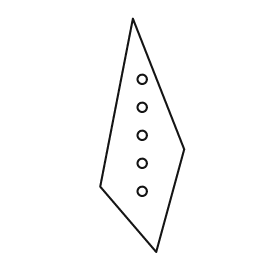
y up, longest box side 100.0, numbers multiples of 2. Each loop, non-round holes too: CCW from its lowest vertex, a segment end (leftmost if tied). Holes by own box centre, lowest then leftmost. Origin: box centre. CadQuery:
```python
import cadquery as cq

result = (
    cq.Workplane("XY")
    .moveTo(6.0, -50.0)
    .lineTo(18.0, -6.0)
    .lineTo(-4.0, 50.0)
    .lineTo(-18.0, -22.0)
    .close()
    .moveTo(0.0, -24.0)
    .circle(2.0)
    .moveTo(0.0, -12.0)
    .circle(2.0)
    .moveTo(0.0, 0.0)
    .circle(2.0)
    .moveTo(0.0, 12.0)
    .circle(2.0)
    .moveTo(0.0, 24.0)
    .circle(2.0)
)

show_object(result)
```